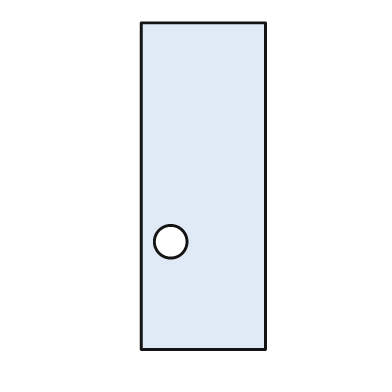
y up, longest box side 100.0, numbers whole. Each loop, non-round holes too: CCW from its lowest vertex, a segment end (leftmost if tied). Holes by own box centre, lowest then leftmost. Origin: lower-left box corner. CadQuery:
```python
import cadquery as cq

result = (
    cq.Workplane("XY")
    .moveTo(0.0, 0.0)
    .lineTo(38.0, 0.0)
    .lineTo(38.0, 100.0)
    .lineTo(0.0, 100.0)
    .close()
    .moveTo(9.0, 33.0)
    .circle(5.0)
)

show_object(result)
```